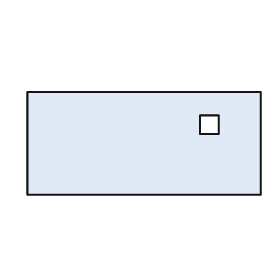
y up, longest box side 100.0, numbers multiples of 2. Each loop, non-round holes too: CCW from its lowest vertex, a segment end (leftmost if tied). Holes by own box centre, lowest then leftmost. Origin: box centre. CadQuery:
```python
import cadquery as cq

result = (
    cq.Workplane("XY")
    .moveTo(-50.0, -22.0)
    .lineTo(50.0, -22.0)
    .lineTo(50.0, 22.0)
    .lineTo(-50.0, 22.0)
    .close()
    .moveTo(24.0, 4.0)
    .lineTo(32.0, 4.0)
    .lineTo(32.0, 12.0)
    .lineTo(24.0, 12.0)
    .close()
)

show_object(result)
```